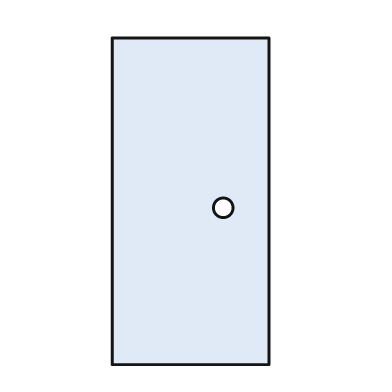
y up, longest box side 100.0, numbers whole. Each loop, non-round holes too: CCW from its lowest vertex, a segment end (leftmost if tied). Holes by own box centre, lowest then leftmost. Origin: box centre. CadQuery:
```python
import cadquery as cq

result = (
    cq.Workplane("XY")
    .moveTo(-24.0, -50.0)
    .lineTo(24.0, -50.0)
    .lineTo(24.0, 50.0)
    .lineTo(-24.0, 50.0)
    .close()
    .moveTo(10.0, -2.0)
    .circle(3.0)
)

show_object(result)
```